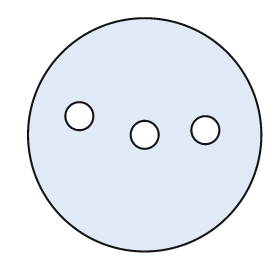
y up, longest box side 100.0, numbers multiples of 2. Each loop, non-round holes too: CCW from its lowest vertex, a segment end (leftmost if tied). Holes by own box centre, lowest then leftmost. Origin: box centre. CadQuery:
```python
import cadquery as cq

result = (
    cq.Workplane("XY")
    .moveTo(0.0, 0.0)
    .circle(50.0)
    .moveTo(0.0, 0.0)
    .circle(6.0)
    .moveTo(26.0, 2.0)
    .circle(6.0)
    .moveTo(-28.0, 8.0)
    .circle(6.0)
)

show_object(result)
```